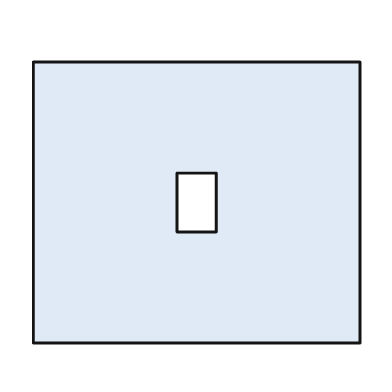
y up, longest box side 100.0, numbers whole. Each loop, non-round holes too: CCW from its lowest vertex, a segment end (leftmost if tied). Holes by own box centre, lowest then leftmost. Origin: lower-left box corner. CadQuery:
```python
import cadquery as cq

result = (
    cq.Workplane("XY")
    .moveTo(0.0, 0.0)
    .lineTo(100.0, 0.0)
    .lineTo(100.0, 86.0)
    .lineTo(0.0, 86.0)
    .close()
    .moveTo(44.0, 34.0)
    .lineTo(56.0, 34.0)
    .lineTo(56.0, 52.0)
    .lineTo(44.0, 52.0)
    .close()
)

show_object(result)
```